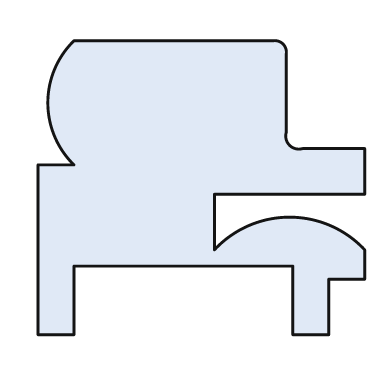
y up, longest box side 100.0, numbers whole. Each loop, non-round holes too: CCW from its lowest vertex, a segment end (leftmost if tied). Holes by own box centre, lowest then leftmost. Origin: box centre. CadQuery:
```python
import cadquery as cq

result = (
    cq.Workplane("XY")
    .moveTo(-50.0, -45.0)
    .lineTo(-39.0, -45.0)
    .lineTo(-39.0, -24.0)
    .lineTo(28.0, -24.0)
    .lineTo(28.0, -45.0)
    .lineTo(39.0, -45.0)
    .lineTo(39.0, -28.0)
    .lineTo(50.0, -28.0)
    .lineTo(50.0, -19.0)
    .threePointArc((27.0, -9.0), (4.0, -19.0))
    .lineTo(4.0, -2.0)
    .lineTo(50.0, -2.0)
    .lineTo(50.0, 12.0)
    .lineTo(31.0, 12.0)
    .threePointArc((27.0, 13.0), (26.0, 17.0))
    .lineTo(26.0, 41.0)
    .threePointArc((25.0, 44.0), (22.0, 45.0))
    .lineTo(-39.0, 45.0)
    .threePointArc((-47.0, 26.0), (-39.0, 7.0))
    .lineTo(-50.0, 7.0)
    .close()
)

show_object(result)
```